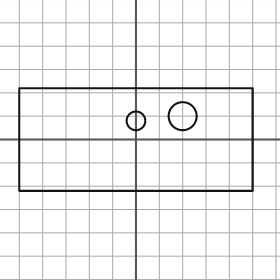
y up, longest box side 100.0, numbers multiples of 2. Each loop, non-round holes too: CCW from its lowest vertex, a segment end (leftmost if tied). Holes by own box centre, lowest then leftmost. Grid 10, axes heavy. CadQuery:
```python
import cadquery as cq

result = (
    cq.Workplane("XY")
    .moveTo(-50.0, -22.0)
    .lineTo(50.0, -22.0)
    .lineTo(50.0, 22.0)
    .lineTo(-50.0, 22.0)
    .close()
    .moveTo(0.0, 8.0)
    .circle(4.0)
    .moveTo(20.0, 10.0)
    .circle(6.0)
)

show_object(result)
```